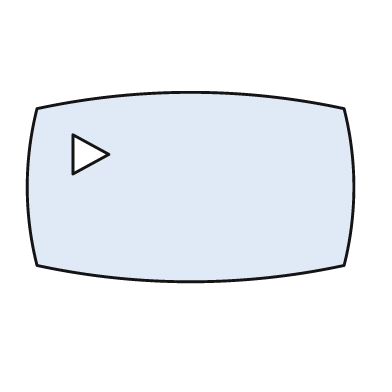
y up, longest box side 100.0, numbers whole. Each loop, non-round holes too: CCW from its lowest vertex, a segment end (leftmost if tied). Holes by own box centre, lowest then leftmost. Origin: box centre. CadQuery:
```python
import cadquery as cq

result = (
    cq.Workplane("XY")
    .moveTo(-47.0, -24.0)
    .threePointArc((0.0, -29.0), (47.0, -24.0))
    .threePointArc((50.0, 0.0), (47.0, 24.0))
    .threePointArc((0.0, 29.0), (-47.0, 24.0))
    .threePointArc((-50.0, 0.0), (-47.0, -24.0))
    .close()
    .moveTo(-36.0, 4.0)
    .lineTo(-25.0, 10.0)
    .lineTo(-36.0, 16.0)
    .close()
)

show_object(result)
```